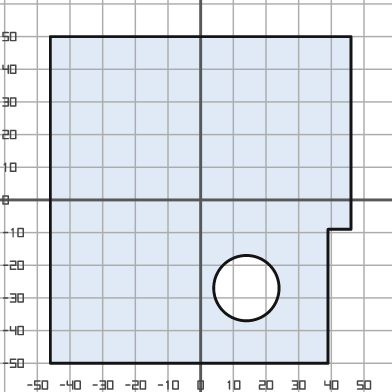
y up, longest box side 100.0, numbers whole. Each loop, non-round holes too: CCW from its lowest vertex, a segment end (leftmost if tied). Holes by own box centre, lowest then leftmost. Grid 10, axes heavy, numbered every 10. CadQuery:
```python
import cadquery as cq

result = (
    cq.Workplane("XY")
    .moveTo(-46.0, -50.0)
    .lineTo(39.0, -50.0)
    .lineTo(39.0, -9.0)
    .lineTo(46.0, -9.0)
    .lineTo(46.0, 50.0)
    .lineTo(-46.0, 50.0)
    .close()
    .moveTo(14.0, -27.0)
    .circle(10.0)
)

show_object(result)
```